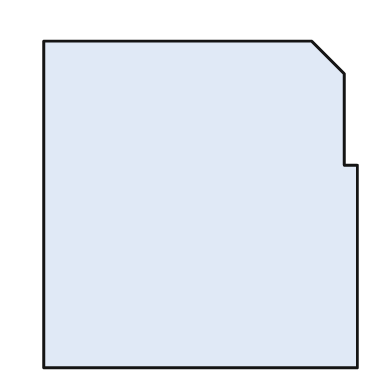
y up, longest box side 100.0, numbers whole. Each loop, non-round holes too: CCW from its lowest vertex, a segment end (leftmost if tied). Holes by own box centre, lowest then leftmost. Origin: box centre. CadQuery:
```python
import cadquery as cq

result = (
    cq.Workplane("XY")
    .moveTo(-48.0, -50.0)
    .lineTo(48.0, -50.0)
    .lineTo(48.0, 12.0)
    .lineTo(44.0, 12.0)
    .lineTo(44.0, 40.0)
    .lineTo(34.0, 50.0)
    .lineTo(-48.0, 50.0)
    .close()
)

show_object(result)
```